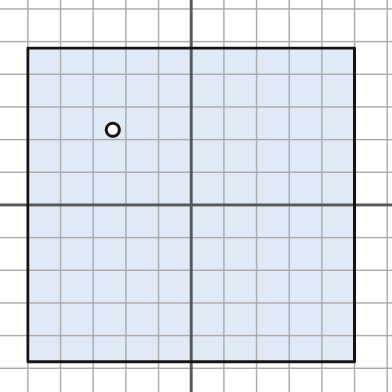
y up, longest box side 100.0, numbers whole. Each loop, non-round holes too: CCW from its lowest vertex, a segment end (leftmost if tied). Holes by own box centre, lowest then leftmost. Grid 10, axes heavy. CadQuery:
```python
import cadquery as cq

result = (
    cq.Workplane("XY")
    .moveTo(-50.0, -48.0)
    .lineTo(50.0, -48.0)
    .lineTo(50.0, 48.0)
    .lineTo(-50.0, 48.0)
    .close()
    .moveTo(-24.0, 23.0)
    .circle(2.0)
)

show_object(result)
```